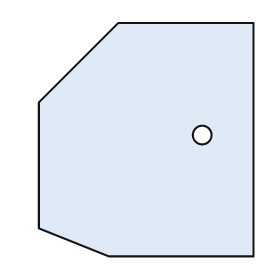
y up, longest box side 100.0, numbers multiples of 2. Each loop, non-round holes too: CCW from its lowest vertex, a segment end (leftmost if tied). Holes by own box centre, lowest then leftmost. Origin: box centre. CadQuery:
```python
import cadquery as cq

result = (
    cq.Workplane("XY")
    .moveTo(-16.0, -50.0)
    .lineTo(46.0, -50.0)
    .lineTo(46.0, 50.0)
    .lineTo(-12.0, 50.0)
    .lineTo(-46.0, 16.0)
    .lineTo(-46.0, -38.0)
    .close()
    .moveTo(24.0, 2.0)
    .circle(4.0)
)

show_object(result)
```